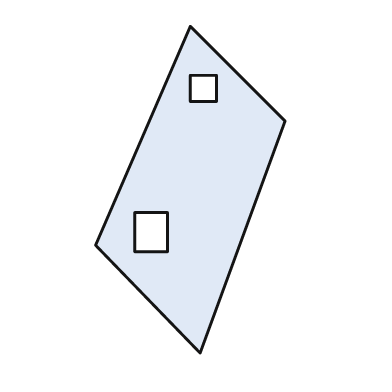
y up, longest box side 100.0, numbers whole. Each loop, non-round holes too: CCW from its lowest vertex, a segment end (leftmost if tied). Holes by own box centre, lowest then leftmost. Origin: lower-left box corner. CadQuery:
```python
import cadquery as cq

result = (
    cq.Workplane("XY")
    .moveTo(32.0, 0.0)
    .lineTo(58.0, 71.0)
    .lineTo(29.0, 100.0)
    .lineTo(0.0, 33.0)
    .close()
    .moveTo(12.0, 31.0)
    .lineTo(22.0, 31.0)
    .lineTo(22.0, 43.0)
    .lineTo(12.0, 43.0)
    .close()
    .moveTo(29.0, 77.0)
    .lineTo(37.0, 77.0)
    .lineTo(37.0, 85.0)
    .lineTo(29.0, 85.0)
    .close()
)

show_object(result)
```